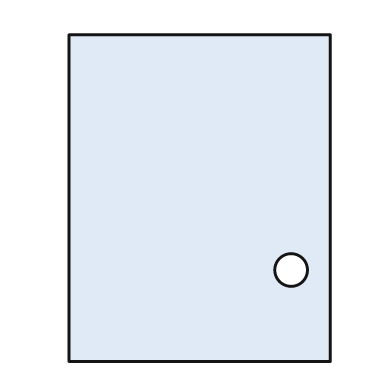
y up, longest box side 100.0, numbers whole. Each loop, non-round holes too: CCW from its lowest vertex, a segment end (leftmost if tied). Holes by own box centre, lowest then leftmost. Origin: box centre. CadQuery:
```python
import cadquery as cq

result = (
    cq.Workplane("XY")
    .moveTo(-40.0, -50.0)
    .lineTo(40.0, -50.0)
    .lineTo(40.0, 50.0)
    .lineTo(-40.0, 50.0)
    .close()
    .moveTo(28.0, -22.0)
    .circle(5.0)
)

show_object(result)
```